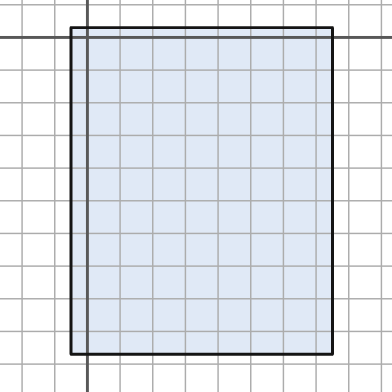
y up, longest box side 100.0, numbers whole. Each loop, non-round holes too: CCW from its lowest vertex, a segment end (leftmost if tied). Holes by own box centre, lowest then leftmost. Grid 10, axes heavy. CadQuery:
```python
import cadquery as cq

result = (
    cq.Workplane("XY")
    .moveTo(-5.0, -97.0)
    .lineTo(75.0, -97.0)
    .lineTo(75.0, 3.0)
    .lineTo(-5.0, 3.0)
    .close()
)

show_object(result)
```